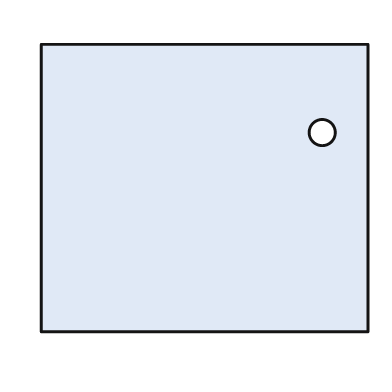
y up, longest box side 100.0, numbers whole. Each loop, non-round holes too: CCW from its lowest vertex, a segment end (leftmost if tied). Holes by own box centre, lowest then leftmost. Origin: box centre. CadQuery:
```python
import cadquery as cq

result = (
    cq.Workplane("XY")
    .moveTo(-50.0, -44.0)
    .lineTo(50.0, -44.0)
    .lineTo(50.0, 44.0)
    .lineTo(-50.0, 44.0)
    .close()
    .moveTo(36.0, 17.0)
    .circle(4.0)
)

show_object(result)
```